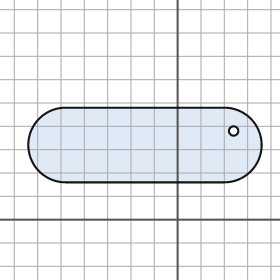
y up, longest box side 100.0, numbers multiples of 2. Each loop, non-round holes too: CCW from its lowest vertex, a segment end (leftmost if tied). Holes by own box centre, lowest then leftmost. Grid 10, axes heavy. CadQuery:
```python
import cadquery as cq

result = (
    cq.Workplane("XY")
    .moveTo(-48.0, 16.0)
    .lineTo(20.0, 16.0)
    .threePointArc((36.0, 32.0), (20.0, 48.0))
    .lineTo(-48.0, 48.0)
    .threePointArc((-64.0, 32.0), (-48.0, 16.0))
    .close()
    .moveTo(24.0, 38.0)
    .circle(2.0)
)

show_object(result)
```